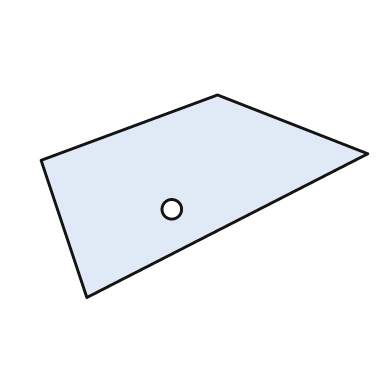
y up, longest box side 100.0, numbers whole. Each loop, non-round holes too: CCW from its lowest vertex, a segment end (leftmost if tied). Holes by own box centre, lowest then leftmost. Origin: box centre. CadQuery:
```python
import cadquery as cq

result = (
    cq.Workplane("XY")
    .moveTo(-36.0, -31.0)
    .lineTo(50.0, 13.0)
    .lineTo(4.0, 31.0)
    .lineTo(-50.0, 11.0)
    .close()
    .moveTo(-10.0, -4.0)
    .circle(3.0)
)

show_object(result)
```